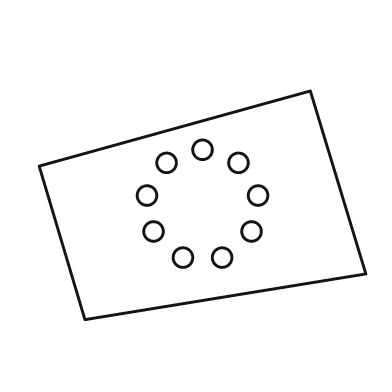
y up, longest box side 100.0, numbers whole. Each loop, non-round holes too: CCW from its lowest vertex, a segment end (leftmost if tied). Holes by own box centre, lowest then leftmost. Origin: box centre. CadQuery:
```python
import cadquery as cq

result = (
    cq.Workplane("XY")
    .moveTo(-36.0, -35.0)
    .lineTo(50.0, -21.0)
    .lineTo(33.0, 35.0)
    .lineTo(-50.0, 12.0)
    .close()
    .moveTo(-6.0, -16.0)
    .circle(3.0)
    .moveTo(6.0, -16.0)
    .circle(3.0)
    .moveTo(-15.0, -8.0)
    .circle(3.0)
    .moveTo(15.0, -8.0)
    .circle(3.0)
    .moveTo(-17.0, 3.0)
    .circle(3.0)
    .moveTo(17.0, 3.0)
    .circle(3.0)
    .moveTo(-11.0, 13.0)
    .circle(3.0)
    .moveTo(11.0, 13.0)
    .circle(3.0)
    .moveTo(0.0, 17.0)
    .circle(3.0)
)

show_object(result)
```